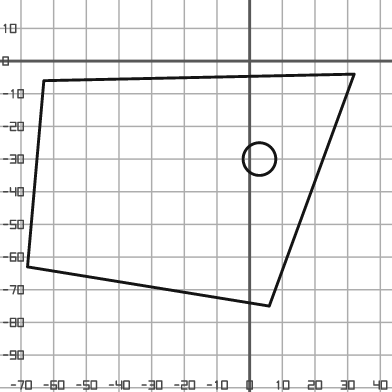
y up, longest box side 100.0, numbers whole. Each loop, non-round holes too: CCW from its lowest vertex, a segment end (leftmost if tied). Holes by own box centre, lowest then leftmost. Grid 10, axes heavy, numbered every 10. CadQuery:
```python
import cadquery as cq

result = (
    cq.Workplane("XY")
    .moveTo(6.0, -75.0)
    .lineTo(32.0, -4.0)
    .lineTo(-63.0, -6.0)
    .lineTo(-68.0, -63.0)
    .close()
    .moveTo(3.0, -30.0)
    .circle(5.0)
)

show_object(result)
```